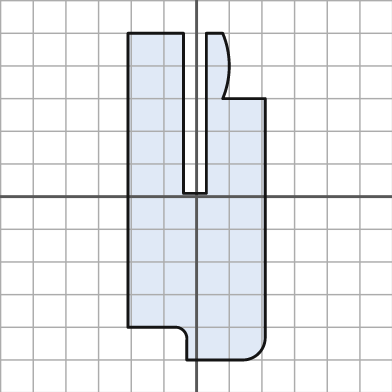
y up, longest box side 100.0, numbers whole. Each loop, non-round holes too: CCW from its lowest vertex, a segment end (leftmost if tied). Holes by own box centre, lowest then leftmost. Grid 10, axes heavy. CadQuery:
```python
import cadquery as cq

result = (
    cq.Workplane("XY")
    .moveTo(-3.0, -50.0)
    .lineTo(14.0, -50.0)
    .threePointArc((19.0, -48.0), (21.0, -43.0))
    .lineTo(21.0, 30.0)
    .lineTo(8.0, 30.0)
    .threePointArc((10.0, 40.0), (8.0, 50.0))
    .lineTo(3.0, 50.0)
    .lineTo(3.0, 1.0)
    .lineTo(-4.0, 1.0)
    .lineTo(-4.0, 50.0)
    .lineTo(-21.0, 50.0)
    .lineTo(-21.0, -40.0)
    .lineTo(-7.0, -40.0)
    .threePointArc((-4.0, -41.0), (-3.0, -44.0))
    .close()
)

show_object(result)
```